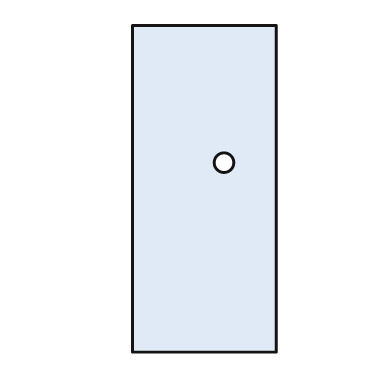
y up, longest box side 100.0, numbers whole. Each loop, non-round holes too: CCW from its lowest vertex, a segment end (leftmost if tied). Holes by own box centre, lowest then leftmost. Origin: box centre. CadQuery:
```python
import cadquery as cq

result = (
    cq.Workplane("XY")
    .moveTo(-22.0, -50.0)
    .lineTo(22.0, -50.0)
    .lineTo(22.0, 50.0)
    .lineTo(-22.0, 50.0)
    .close()
    .moveTo(6.0, 8.0)
    .circle(3.0)
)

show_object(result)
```